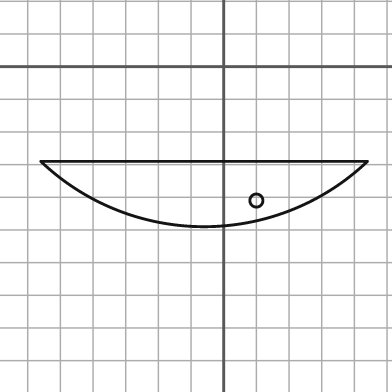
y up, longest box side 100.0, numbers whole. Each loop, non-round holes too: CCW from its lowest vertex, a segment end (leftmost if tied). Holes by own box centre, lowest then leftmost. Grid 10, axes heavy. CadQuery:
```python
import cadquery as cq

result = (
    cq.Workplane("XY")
    .moveTo(-56.0, -29.0)
    .threePointArc((-6.0, -49.0), (44.0, -29.0))
    .close()
    .moveTo(10.0, -41.0)
    .circle(2.0)
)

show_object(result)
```